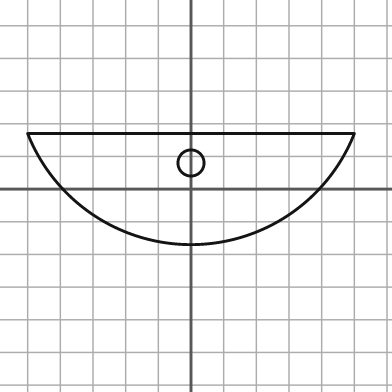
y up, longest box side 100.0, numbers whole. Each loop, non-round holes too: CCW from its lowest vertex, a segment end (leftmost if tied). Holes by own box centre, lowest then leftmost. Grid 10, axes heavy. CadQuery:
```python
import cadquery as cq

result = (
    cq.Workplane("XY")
    .moveTo(-50.0, 17.0)
    .threePointArc((0.0, -17.0), (50.0, 17.0))
    .close()
    .moveTo(0.0, 8.0)
    .circle(4.0)
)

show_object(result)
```